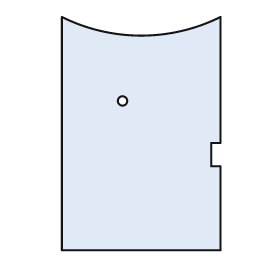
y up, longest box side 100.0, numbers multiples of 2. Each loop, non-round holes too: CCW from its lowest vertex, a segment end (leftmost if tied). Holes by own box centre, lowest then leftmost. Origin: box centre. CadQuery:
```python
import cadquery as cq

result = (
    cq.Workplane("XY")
    .moveTo(-34.0, -50.0)
    .lineTo(34.0, -50.0)
    .lineTo(34.0, -14.0)
    .lineTo(30.0, -14.0)
    .lineTo(30.0, -4.0)
    .lineTo(34.0, -4.0)
    .lineTo(34.0, 50.0)
    .threePointArc((0.0, 42.0), (-34.0, 50.0))
    .close()
    .moveTo(-8.0, 14.0)
    .circle(2.0)
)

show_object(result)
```